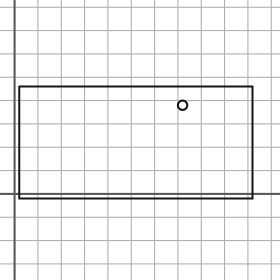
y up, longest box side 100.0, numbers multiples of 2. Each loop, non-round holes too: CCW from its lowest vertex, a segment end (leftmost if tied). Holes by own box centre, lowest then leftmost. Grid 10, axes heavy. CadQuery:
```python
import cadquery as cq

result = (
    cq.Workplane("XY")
    .moveTo(2.0, -2.0)
    .lineTo(102.0, -2.0)
    .lineTo(102.0, 46.0)
    .lineTo(2.0, 46.0)
    .close()
    .moveTo(72.0, 38.0)
    .circle(2.0)
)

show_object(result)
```